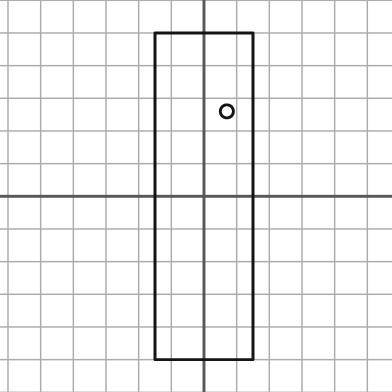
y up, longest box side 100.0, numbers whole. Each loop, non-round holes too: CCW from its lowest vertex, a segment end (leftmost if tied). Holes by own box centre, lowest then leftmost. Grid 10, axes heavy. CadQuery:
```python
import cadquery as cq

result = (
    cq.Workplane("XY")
    .moveTo(-15.0, -50.0)
    .lineTo(15.0, -50.0)
    .lineTo(15.0, 50.0)
    .lineTo(-15.0, 50.0)
    .close()
    .moveTo(7.0, 26.0)
    .circle(2.0)
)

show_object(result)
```